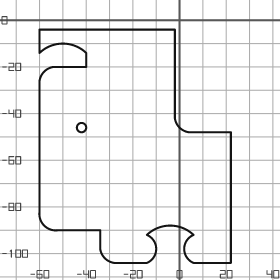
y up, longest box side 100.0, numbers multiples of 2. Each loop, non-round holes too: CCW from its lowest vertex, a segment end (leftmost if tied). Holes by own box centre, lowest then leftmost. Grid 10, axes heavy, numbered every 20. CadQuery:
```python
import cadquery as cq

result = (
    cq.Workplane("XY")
    .moveTo(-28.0, -104.0)
    .lineTo(-14.0, -104.0)
    .threePointArc((-10.0, -98.0), (-14.0, -92.0))
    .threePointArc((-4.0, -88.0), (6.0, -92.0))
    .threePointArc((2.0, -98.0), (6.0, -104.0))
    .lineTo(22.0, -104.0)
    .lineTo(22.0, -48.0)
    .lineTo(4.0, -48.0)
    .threePointArc((0.0, -46.0), (-2.0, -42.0))
    .lineTo(-2.0, -4.0)
    .lineTo(-60.0, -4.0)
    .lineTo(-60.0, -14.0)
    .threePointArc((-50.0, -10.0), (-40.0, -14.0))
    .lineTo(-40.0, -20.0)
    .lineTo(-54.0, -20.0)
    .threePointArc((-58.0, -22.0), (-60.0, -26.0))
    .lineTo(-60.0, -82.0)
    .threePointArc((-58.0, -88.0), (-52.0, -90.0))
    .lineTo(-34.0, -90.0)
    .lineTo(-34.0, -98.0)
    .threePointArc((-32.0, -102.0), (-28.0, -104.0))
    .close()
    .moveTo(-42.0, -46.0)
    .circle(2.0)
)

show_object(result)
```